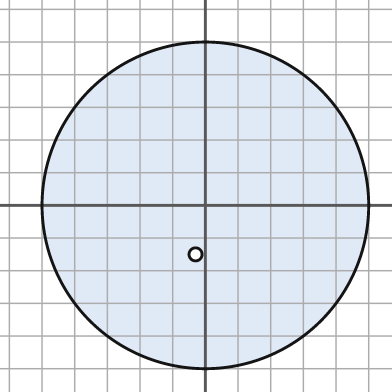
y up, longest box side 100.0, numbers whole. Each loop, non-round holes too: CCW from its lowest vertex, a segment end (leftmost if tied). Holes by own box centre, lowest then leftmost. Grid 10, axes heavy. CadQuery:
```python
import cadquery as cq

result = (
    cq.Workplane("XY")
    .moveTo(0.0, 0.0)
    .circle(50.0)
    .moveTo(-3.0, -15.0)
    .circle(2.0)
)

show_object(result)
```